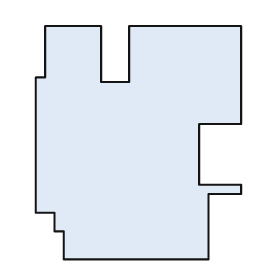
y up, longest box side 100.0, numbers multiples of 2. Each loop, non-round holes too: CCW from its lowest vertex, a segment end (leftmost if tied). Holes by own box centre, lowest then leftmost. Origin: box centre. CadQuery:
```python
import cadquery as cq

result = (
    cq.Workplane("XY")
    .moveTo(-32.0, -50.0)
    .lineTo(30.0, -50.0)
    .lineTo(30.0, -22.0)
    .lineTo(44.0, -22.0)
    .lineTo(44.0, -18.0)
    .lineTo(26.0, -18.0)
    .lineTo(26.0, 8.0)
    .lineTo(44.0, 8.0)
    .lineTo(44.0, 50.0)
    .lineTo(-4.0, 50.0)
    .lineTo(-4.0, 26.0)
    .lineTo(-16.0, 26.0)
    .lineTo(-16.0, 50.0)
    .lineTo(-40.0, 50.0)
    .lineTo(-40.0, 28.0)
    .lineTo(-44.0, 28.0)
    .lineTo(-44.0, -30.0)
    .lineTo(-36.0, -30.0)
    .lineTo(-36.0, -38.0)
    .lineTo(-32.0, -38.0)
    .close()
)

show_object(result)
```